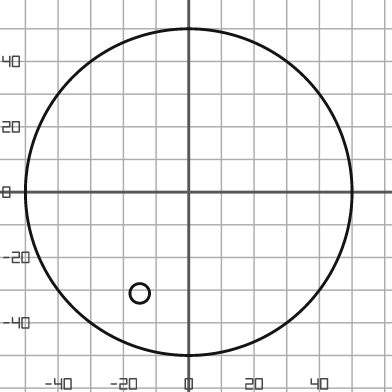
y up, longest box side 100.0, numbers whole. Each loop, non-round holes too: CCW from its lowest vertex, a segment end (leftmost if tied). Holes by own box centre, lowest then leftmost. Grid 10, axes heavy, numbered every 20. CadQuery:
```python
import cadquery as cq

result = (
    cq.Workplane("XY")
    .moveTo(0.0, 0.0)
    .circle(50.0)
    .moveTo(-15.0, -31.0)
    .circle(3.0)
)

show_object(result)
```